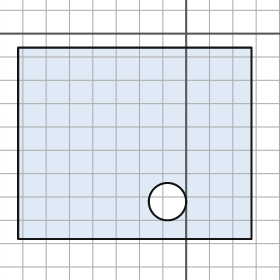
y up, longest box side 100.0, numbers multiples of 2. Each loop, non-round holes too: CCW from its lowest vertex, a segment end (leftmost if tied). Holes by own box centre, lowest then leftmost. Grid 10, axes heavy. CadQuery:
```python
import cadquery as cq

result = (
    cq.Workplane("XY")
    .moveTo(-72.0, -88.0)
    .lineTo(28.0, -88.0)
    .lineTo(28.0, -6.0)
    .lineTo(-72.0, -6.0)
    .close()
    .moveTo(-8.0, -72.0)
    .circle(8.0)
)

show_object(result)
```